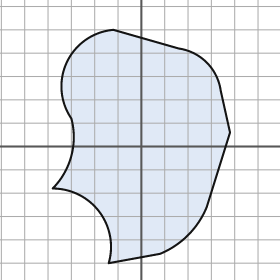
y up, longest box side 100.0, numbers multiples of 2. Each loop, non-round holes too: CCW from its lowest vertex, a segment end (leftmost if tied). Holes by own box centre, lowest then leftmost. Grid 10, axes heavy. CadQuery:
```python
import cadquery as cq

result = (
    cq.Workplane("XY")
    .moveTo(-14.0, -50.0)
    .lineTo(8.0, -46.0)
    .threePointArc((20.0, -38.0), (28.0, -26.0))
    .lineTo(38.0, 6.0)
    .lineTo(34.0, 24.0)
    .threePointArc((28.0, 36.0), (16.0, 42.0))
    .lineTo(-12.0, 50.0)
    .threePointArc((-32.0, 36.0), (-30.0, 12.0))
    .threePointArc((-30.0, -4.0), (-38.0, -18.0))
    .threePointArc((-18.0, -28.0), (-14.0, -50.0))
    .close()
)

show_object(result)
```